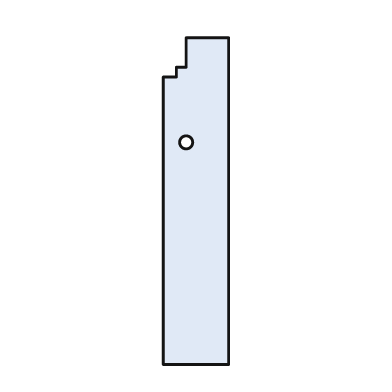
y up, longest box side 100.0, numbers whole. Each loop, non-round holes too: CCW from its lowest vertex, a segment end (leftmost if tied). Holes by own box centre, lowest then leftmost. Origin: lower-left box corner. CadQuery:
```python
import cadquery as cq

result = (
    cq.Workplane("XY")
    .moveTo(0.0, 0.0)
    .lineTo(20.0, 0.0)
    .lineTo(20.0, 100.0)
    .lineTo(7.0, 100.0)
    .lineTo(7.0, 91.0)
    .lineTo(4.0, 91.0)
    .lineTo(4.0, 88.0)
    .lineTo(0.0, 88.0)
    .close()
    .moveTo(7.0, 68.0)
    .circle(2.0)
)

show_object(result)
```